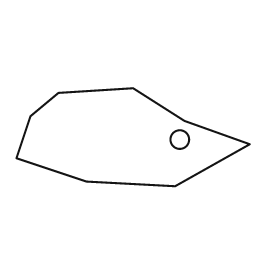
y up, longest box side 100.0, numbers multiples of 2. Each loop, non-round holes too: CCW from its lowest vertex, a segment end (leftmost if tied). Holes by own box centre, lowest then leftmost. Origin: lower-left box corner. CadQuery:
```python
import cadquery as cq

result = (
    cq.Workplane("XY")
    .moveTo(68.0, 0.0)
    .lineTo(100.0, 18.0)
    .lineTo(72.0, 28.0)
    .lineTo(50.0, 42.0)
    .lineTo(18.0, 40.0)
    .lineTo(6.0, 30.0)
    .lineTo(0.0, 12.0)
    .lineTo(30.0, 2.0)
    .close()
    .moveTo(70.0, 20.0)
    .circle(4.0)
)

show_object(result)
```